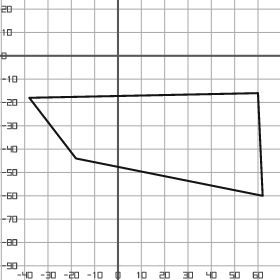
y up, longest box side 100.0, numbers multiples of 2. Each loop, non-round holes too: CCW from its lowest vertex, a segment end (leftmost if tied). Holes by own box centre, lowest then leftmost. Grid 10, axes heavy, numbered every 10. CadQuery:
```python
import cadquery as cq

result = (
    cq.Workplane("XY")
    .moveTo(62.0, -60.0)
    .lineTo(60.0, -16.0)
    .lineTo(-38.0, -18.0)
    .lineTo(-18.0, -44.0)
    .close()
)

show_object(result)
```